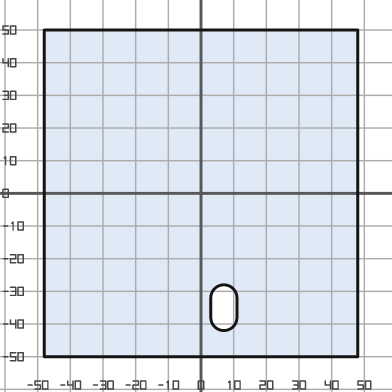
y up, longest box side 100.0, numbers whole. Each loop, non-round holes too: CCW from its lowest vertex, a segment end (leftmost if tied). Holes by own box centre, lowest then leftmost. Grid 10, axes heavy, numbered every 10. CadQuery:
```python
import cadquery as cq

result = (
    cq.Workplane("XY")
    .moveTo(-48.0, -50.0)
    .lineTo(48.0, -50.0)
    .lineTo(48.0, 50.0)
    .lineTo(-48.0, 50.0)
    .close()
    .moveTo(3.0, -38.0)
    .threePointArc((7.0, -42.0), (11.0, -38.0))
    .lineTo(11.0, -32.0)
    .threePointArc((7.0, -28.0), (3.0, -32.0))
    .close()
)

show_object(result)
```